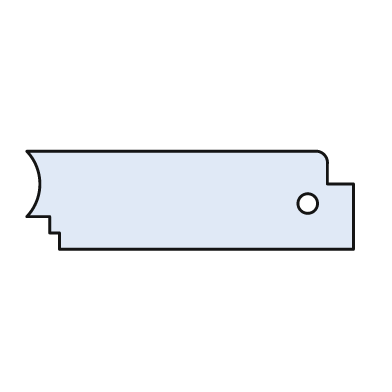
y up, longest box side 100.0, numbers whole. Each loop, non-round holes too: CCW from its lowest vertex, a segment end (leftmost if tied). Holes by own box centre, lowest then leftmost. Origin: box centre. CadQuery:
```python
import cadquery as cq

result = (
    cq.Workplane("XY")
    .moveTo(-40.0, -15.0)
    .lineTo(50.0, -15.0)
    .lineTo(50.0, 5.0)
    .lineTo(42.0, 5.0)
    .lineTo(42.0, 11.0)
    .threePointArc((41.0, 14.0), (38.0, 15.0))
    .lineTo(-50.0, 15.0)
    .threePointArc((-46.0, 5.0), (-50.0, -5.0))
    .lineTo(-43.0, -5.0)
    .lineTo(-43.0, -10.0)
    .lineTo(-40.0, -10.0)
    .close()
    .moveTo(36.0, -1.0)
    .circle(3.0)
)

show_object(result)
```